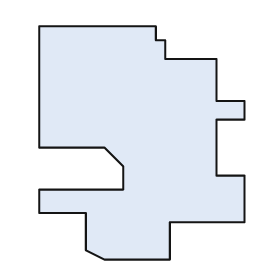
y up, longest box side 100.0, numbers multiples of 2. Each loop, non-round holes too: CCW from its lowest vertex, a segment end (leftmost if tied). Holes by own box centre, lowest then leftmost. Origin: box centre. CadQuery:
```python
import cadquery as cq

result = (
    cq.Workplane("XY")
    .moveTo(-16.0, -50.0)
    .lineTo(12.0, -50.0)
    .lineTo(12.0, -34.0)
    .lineTo(44.0, -34.0)
    .lineTo(44.0, -14.0)
    .lineTo(32.0, -14.0)
    .lineTo(32.0, 10.0)
    .lineTo(44.0, 10.0)
    .lineTo(44.0, 18.0)
    .lineTo(32.0, 18.0)
    .lineTo(32.0, 36.0)
    .lineTo(10.0, 36.0)
    .lineTo(10.0, 44.0)
    .lineTo(6.0, 44.0)
    .lineTo(6.0, 50.0)
    .lineTo(-44.0, 50.0)
    .lineTo(-44.0, -2.0)
    .lineTo(-16.0, -2.0)
    .lineTo(-8.0, -10.0)
    .lineTo(-8.0, -20.0)
    .lineTo(-44.0, -20.0)
    .lineTo(-44.0, -30.0)
    .lineTo(-24.0, -30.0)
    .lineTo(-24.0, -46.0)
    .close()
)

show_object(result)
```